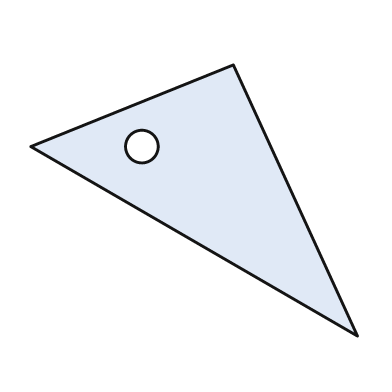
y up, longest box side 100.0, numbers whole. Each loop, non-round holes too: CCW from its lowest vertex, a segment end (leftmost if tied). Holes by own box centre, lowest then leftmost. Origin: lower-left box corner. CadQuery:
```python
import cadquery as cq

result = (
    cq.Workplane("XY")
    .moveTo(100.0, 0.0)
    .lineTo(62.0, 83.0)
    .lineTo(0.0, 58.0)
    .close()
    .moveTo(34.0, 58.0)
    .circle(5.0)
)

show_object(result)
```